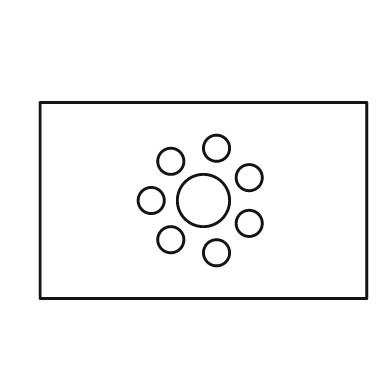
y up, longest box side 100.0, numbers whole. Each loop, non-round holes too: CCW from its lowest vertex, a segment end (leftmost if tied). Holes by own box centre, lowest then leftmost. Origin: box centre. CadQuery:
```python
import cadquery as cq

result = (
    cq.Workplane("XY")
    .moveTo(-50.0, -30.0)
    .lineTo(50.0, -30.0)
    .lineTo(50.0, 30.0)
    .lineTo(-50.0, 30.0)
    .close()
    .moveTo(4.0, -16.0)
    .circle(4.0)
    .moveTo(-10.0, -12.0)
    .circle(4.0)
    .moveTo(14.0, -7.0)
    .circle(4.0)
    .moveTo(-16.0, 0.0)
    .circle(4.0)
    .moveTo(0.0, 0.0)
    .circle(8.0)
    .moveTo(14.0, 7.0)
    .circle(4.0)
    .moveTo(-10.0, 12.0)
    .circle(4.0)
    .moveTo(4.0, 16.0)
    .circle(4.0)
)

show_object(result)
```